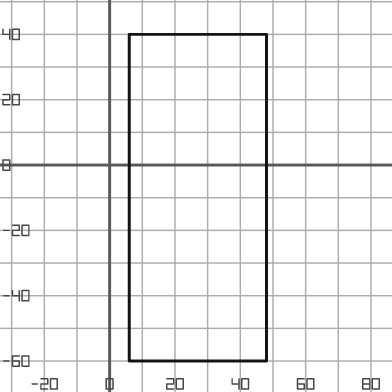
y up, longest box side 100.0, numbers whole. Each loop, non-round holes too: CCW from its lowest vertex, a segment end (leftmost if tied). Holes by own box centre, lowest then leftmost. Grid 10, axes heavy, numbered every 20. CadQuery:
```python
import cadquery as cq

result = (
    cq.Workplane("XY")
    .moveTo(6.0, -60.0)
    .lineTo(48.0, -60.0)
    .lineTo(48.0, 40.0)
    .lineTo(6.0, 40.0)
    .close()
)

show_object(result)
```